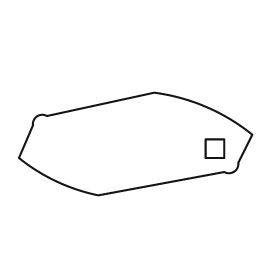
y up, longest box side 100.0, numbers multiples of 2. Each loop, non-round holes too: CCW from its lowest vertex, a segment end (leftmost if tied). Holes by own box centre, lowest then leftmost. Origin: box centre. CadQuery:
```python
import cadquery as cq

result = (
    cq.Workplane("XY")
    .moveTo(-16.0, -22.0)
    .lineTo(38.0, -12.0)
    .threePointArc((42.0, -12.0), (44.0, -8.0))
    .lineTo(50.0, 4.0)
    .threePointArc((30.0, 16.0), (8.0, 22.0))
    .lineTo(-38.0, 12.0)
    .threePointArc((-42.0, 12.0), (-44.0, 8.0))
    .lineTo(-50.0, -6.0)
    .threePointArc((-34.0, -16.0), (-16.0, -22.0))
    .close()
    .moveTo(30.0, -6.0)
    .lineTo(38.0, -6.0)
    .lineTo(38.0, 2.0)
    .lineTo(30.0, 2.0)
    .close()
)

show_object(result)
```